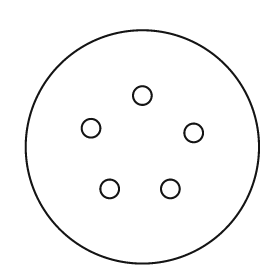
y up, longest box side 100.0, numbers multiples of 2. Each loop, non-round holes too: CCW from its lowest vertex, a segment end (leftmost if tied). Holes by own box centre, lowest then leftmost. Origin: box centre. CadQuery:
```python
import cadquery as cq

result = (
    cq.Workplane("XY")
    .moveTo(0.0, 0.0)
    .circle(50.0)
    .moveTo(-14.0, -18.0)
    .circle(4.0)
    .moveTo(12.0, -18.0)
    .circle(4.0)
    .moveTo(22.0, 6.0)
    .circle(4.0)
    .moveTo(-22.0, 8.0)
    .circle(4.0)
    .moveTo(0.0, 22.0)
    .circle(4.0)
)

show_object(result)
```